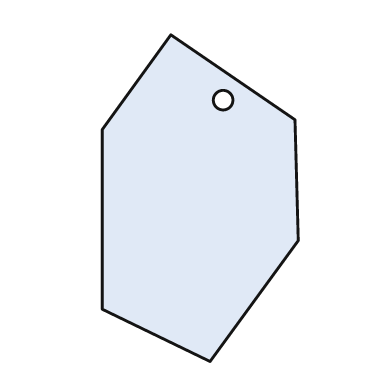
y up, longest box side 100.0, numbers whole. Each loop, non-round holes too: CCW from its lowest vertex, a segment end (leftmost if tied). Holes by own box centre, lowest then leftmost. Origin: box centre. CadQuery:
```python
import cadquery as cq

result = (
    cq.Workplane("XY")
    .moveTo(3.0, -50.0)
    .lineTo(30.0, -13.0)
    .lineTo(29.0, 24.0)
    .lineTo(-9.0, 50.0)
    .lineTo(-30.0, 21.0)
    .lineTo(-30.0, -34.0)
    .close()
    .moveTo(7.0, 30.0)
    .circle(3.0)
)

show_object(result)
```